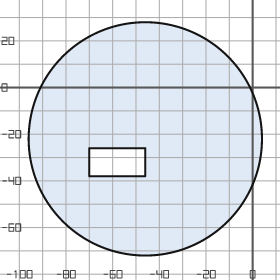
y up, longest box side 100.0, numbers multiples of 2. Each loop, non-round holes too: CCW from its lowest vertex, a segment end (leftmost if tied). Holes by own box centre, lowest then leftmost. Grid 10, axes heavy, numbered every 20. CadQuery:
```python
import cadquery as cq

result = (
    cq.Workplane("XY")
    .moveTo(-46.0, -22.0)
    .circle(50.0)
    .moveTo(-70.0, -38.0)
    .lineTo(-46.0, -38.0)
    .lineTo(-46.0, -26.0)
    .lineTo(-70.0, -26.0)
    .close()
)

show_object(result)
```